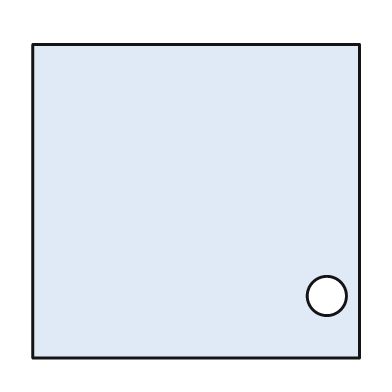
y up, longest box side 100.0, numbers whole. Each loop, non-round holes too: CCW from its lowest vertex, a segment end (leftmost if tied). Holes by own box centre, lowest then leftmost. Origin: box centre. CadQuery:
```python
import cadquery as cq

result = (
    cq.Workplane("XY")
    .moveTo(-50.0, -48.0)
    .lineTo(50.0, -48.0)
    .lineTo(50.0, 48.0)
    .lineTo(-50.0, 48.0)
    .close()
    .moveTo(40.0, -29.0)
    .circle(6.0)
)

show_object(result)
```